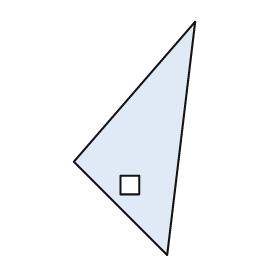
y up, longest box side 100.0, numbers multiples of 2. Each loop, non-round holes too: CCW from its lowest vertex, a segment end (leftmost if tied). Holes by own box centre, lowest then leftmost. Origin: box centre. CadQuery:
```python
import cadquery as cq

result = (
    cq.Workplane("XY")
    .moveTo(14.0, -50.0)
    .lineTo(26.0, 50.0)
    .lineTo(-26.0, -10.0)
    .close()
    .moveTo(-6.0, -24.0)
    .lineTo(2.0, -24.0)
    .lineTo(2.0, -16.0)
    .lineTo(-6.0, -16.0)
    .close()
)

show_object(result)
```